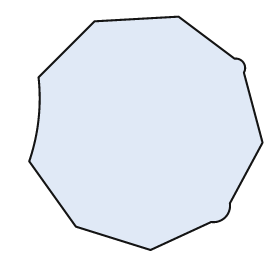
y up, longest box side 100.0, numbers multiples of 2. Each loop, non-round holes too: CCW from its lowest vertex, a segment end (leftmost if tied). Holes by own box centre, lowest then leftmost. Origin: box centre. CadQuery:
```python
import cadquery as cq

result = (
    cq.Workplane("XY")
    .moveTo(2.0, -50.0)
    .lineTo(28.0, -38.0)
    .threePointArc((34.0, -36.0), (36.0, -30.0))
    .lineTo(50.0, -4.0)
    .lineTo(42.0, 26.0)
    .threePointArc((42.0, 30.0), (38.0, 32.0))
    .lineTo(14.0, 50.0)
    .lineTo(-22.0, 48.0)
    .lineTo(-46.0, 24.0)
    .threePointArc((-46.0, 6.0), (-50.0, -12.0))
    .lineTo(-30.0, -40.0)
    .close()
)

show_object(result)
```